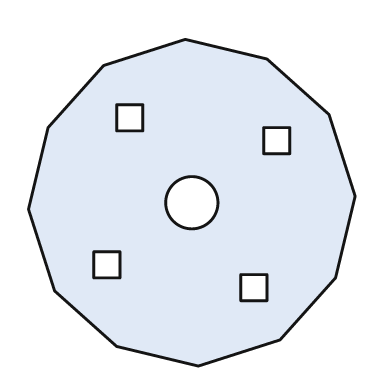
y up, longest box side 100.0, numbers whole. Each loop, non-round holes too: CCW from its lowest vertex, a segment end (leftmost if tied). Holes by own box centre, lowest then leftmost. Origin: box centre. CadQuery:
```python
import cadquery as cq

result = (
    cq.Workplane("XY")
    .moveTo(2.0, -50.0)
    .lineTo(27.0, -42.0)
    .lineTo(44.0, -23.0)
    .lineTo(50.0, 2.0)
    .lineTo(42.0, 27.0)
    .lineTo(23.0, 44.0)
    .lineTo(-2.0, 50.0)
    .lineTo(-27.0, 42.0)
    .lineTo(-44.0, 23.0)
    .lineTo(-50.0, -2.0)
    .lineTo(-42.0, -27.0)
    .lineTo(-23.0, -44.0)
    .close()
    .moveTo(15.0, -30.0)
    .lineTo(23.0, -30.0)
    .lineTo(23.0, -22.0)
    .lineTo(15.0, -22.0)
    .close()
    .moveTo(-30.0, -23.0)
    .lineTo(-22.0, -23.0)
    .lineTo(-22.0, -15.0)
    .lineTo(-30.0, -15.0)
    .close()
    .moveTo(0.0, 0.0)
    .circle(8.0)
    .moveTo(22.0, 15.0)
    .lineTo(30.0, 15.0)
    .lineTo(30.0, 23.0)
    .lineTo(22.0, 23.0)
    .close()
    .moveTo(-23.0, 22.0)
    .lineTo(-15.0, 22.0)
    .lineTo(-15.0, 30.0)
    .lineTo(-23.0, 30.0)
    .close()
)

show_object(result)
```